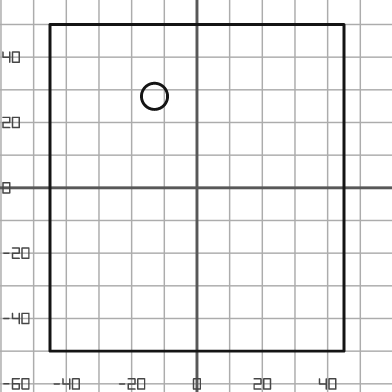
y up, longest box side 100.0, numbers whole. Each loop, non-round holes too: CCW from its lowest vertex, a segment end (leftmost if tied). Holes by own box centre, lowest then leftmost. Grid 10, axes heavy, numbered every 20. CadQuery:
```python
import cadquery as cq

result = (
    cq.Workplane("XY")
    .moveTo(-45.0, -50.0)
    .lineTo(45.0, -50.0)
    .lineTo(45.0, 50.0)
    .lineTo(-45.0, 50.0)
    .close()
    .moveTo(-13.0, 28.0)
    .circle(4.0)
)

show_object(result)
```